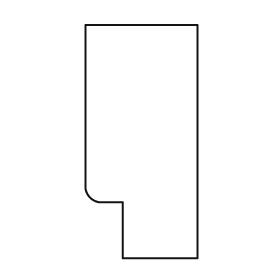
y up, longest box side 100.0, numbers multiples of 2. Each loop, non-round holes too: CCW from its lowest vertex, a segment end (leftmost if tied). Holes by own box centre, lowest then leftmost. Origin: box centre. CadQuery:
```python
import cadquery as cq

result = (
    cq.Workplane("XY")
    .moveTo(-8.0, -50.0)
    .lineTo(24.0, -50.0)
    .lineTo(24.0, 50.0)
    .lineTo(-24.0, 50.0)
    .lineTo(-24.0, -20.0)
    .threePointArc((-22.0, -24.0), (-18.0, -26.0))
    .lineTo(-8.0, -26.0)
    .close()
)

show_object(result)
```